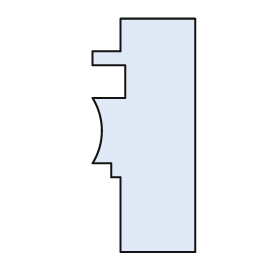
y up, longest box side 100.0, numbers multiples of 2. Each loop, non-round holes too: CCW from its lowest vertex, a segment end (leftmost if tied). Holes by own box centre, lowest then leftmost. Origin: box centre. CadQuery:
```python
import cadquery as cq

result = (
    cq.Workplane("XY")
    .moveTo(-10.0, -50.0)
    .lineTo(22.0, -50.0)
    .lineTo(22.0, 50.0)
    .lineTo(-10.0, 50.0)
    .lineTo(-10.0, 36.0)
    .lineTo(-22.0, 36.0)
    .lineTo(-22.0, 30.0)
    .lineTo(-8.0, 30.0)
    .lineTo(-8.0, 16.0)
    .lineTo(-22.0, 16.0)
    .threePointArc((-18.0, 2.0), (-22.0, -12.0))
    .lineTo(-14.0, -12.0)
    .lineTo(-14.0, -18.0)
    .lineTo(-10.0, -18.0)
    .close()
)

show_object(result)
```